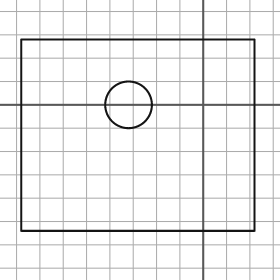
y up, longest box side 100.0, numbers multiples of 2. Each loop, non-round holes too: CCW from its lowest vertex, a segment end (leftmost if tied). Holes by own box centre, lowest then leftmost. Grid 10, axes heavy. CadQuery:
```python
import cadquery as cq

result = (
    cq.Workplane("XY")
    .moveTo(-78.0, -54.0)
    .lineTo(22.0, -54.0)
    .lineTo(22.0, 28.0)
    .lineTo(-78.0, 28.0)
    .close()
    .moveTo(-32.0, 0.0)
    .circle(10.0)
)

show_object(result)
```